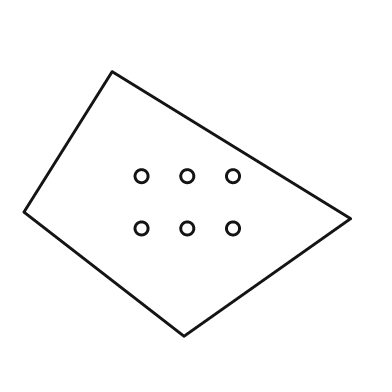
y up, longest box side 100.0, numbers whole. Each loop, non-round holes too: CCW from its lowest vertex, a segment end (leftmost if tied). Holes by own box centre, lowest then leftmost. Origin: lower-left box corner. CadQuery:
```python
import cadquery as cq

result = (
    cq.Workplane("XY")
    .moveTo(49.0, 0.0)
    .lineTo(100.0, 36.0)
    .lineTo(27.0, 81.0)
    .lineTo(0.0, 38.0)
    .close()
    .moveTo(36.0, 33.0)
    .circle(2.0)
    .moveTo(50.0, 33.0)
    .circle(2.0)
    .moveTo(64.0, 33.0)
    .circle(2.0)
    .moveTo(36.0, 49.0)
    .circle(2.0)
    .moveTo(50.0, 49.0)
    .circle(2.0)
    .moveTo(64.0, 49.0)
    .circle(2.0)
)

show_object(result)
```